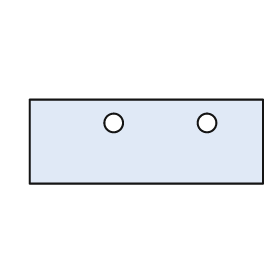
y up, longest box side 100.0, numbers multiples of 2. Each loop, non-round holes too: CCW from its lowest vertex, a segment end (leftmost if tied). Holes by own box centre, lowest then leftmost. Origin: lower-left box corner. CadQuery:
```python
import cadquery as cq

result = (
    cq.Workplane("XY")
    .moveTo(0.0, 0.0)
    .lineTo(100.0, 0.0)
    .lineTo(100.0, 36.0)
    .lineTo(0.0, 36.0)
    .close()
    .moveTo(36.0, 26.0)
    .circle(4.0)
    .moveTo(76.0, 26.0)
    .circle(4.0)
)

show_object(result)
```